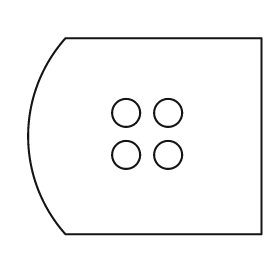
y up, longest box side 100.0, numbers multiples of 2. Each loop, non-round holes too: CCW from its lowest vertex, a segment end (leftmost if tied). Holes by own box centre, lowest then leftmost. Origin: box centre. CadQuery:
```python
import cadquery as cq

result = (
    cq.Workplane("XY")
    .moveTo(-34.0, -42.0)
    .lineTo(50.0, -42.0)
    .lineTo(50.0, 42.0)
    .lineTo(-34.0, 42.0)
    .threePointArc((-50.0, 0.0), (-34.0, -42.0))
    .close()
    .moveTo(-8.0, -8.0)
    .circle(6.0)
    .moveTo(10.0, -8.0)
    .circle(6.0)
    .moveTo(-8.0, 10.0)
    .circle(6.0)
    .moveTo(10.0, 10.0)
    .circle(6.0)
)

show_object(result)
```